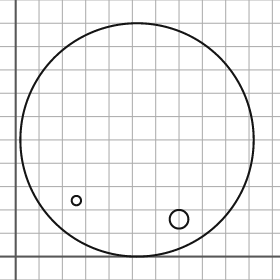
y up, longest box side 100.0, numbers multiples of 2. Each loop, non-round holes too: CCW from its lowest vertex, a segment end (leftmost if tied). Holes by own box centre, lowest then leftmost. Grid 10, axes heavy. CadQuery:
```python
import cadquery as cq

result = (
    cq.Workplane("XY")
    .moveTo(52.0, 50.0)
    .circle(50.0)
    .moveTo(70.0, 16.0)
    .circle(4.0)
    .moveTo(26.0, 24.0)
    .circle(2.0)
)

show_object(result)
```